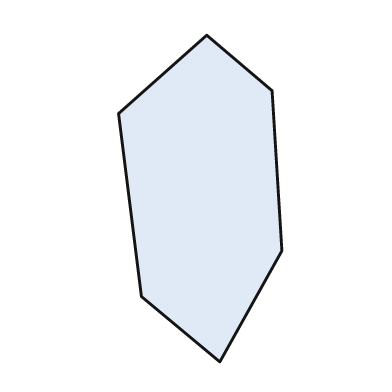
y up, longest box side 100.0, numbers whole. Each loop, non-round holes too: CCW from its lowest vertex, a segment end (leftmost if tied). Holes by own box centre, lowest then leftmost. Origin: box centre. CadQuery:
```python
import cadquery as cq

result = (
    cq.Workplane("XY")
    .moveTo(6.0, -50.0)
    .lineTo(25.0, -16.0)
    .lineTo(22.0, 33.0)
    .lineTo(2.0, 50.0)
    .lineTo(-25.0, 26.0)
    .lineTo(-18.0, -30.0)
    .close()
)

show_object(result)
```